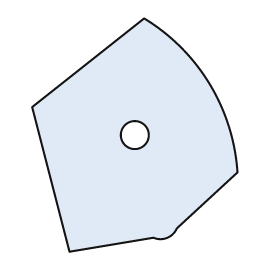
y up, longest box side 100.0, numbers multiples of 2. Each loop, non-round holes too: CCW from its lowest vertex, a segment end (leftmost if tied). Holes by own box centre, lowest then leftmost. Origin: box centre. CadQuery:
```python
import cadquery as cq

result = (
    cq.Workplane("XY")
    .moveTo(-28.0, -50.0)
    .lineTo(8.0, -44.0)
    .threePointArc((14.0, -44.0), (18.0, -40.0))
    .lineTo(44.0, -16.0)
    .threePointArc((32.0, 22.0), (4.0, 50.0))
    .lineTo(-44.0, 12.0)
    .close()
    .moveTo(0.0, 0.0)
    .circle(6.0)
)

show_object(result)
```